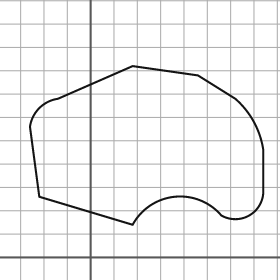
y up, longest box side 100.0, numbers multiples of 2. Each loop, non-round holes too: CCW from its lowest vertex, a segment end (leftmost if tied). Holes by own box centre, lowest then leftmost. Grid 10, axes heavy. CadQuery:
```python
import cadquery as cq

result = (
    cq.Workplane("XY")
    .moveTo(18.0, 14.0)
    .threePointArc((36.0, 26.0), (56.0, 18.0))
    .threePointArc((68.0, 18.0), (74.0, 28.0))
    .lineTo(74.0, 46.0)
    .threePointArc((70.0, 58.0), (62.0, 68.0))
    .lineTo(46.0, 78.0)
    .lineTo(18.0, 82.0)
    .lineTo(-14.0, 68.0)
    .threePointArc((-22.0, 64.0), (-26.0, 56.0))
    .lineTo(-22.0, 26.0)
    .close()
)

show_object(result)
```